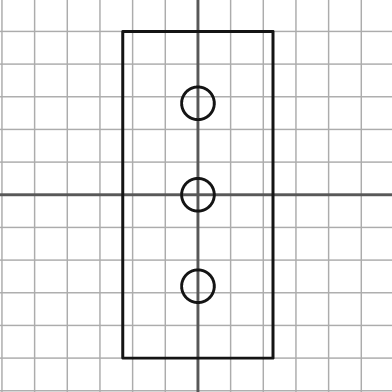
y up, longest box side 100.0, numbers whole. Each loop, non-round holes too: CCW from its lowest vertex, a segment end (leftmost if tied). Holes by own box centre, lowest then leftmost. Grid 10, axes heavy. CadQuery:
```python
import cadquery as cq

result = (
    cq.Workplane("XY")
    .moveTo(-23.0, -50.0)
    .lineTo(23.0, -50.0)
    .lineTo(23.0, 50.0)
    .lineTo(-23.0, 50.0)
    .close()
    .moveTo(0.0, -28.0)
    .circle(5.0)
    .moveTo(0.0, 0.0)
    .circle(5.0)
    .moveTo(0.0, 28.0)
    .circle(5.0)
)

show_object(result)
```